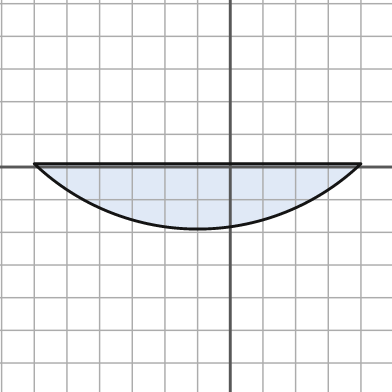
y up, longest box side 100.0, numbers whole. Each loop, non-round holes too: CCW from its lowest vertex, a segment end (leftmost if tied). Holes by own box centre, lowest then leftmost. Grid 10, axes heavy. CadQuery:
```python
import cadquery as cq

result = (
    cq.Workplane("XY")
    .moveTo(-60.0, 1.0)
    .threePointArc((-10.0, -19.0), (40.0, 1.0))
    .close()
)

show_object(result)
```